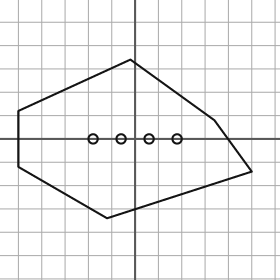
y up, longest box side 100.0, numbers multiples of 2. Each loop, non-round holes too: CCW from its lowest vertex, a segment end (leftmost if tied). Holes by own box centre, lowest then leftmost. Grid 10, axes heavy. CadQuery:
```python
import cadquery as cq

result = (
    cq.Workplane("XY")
    .moveTo(-12.0, -34.0)
    .lineTo(50.0, -14.0)
    .lineTo(34.0, 8.0)
    .lineTo(-2.0, 34.0)
    .lineTo(-50.0, 12.0)
    .lineTo(-50.0, -12.0)
    .close()
    .moveTo(-18.0, 0.0)
    .circle(2.0)
    .moveTo(-6.0, 0.0)
    .circle(2.0)
    .moveTo(6.0, 0.0)
    .circle(2.0)
    .moveTo(18.0, 0.0)
    .circle(2.0)
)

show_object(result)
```